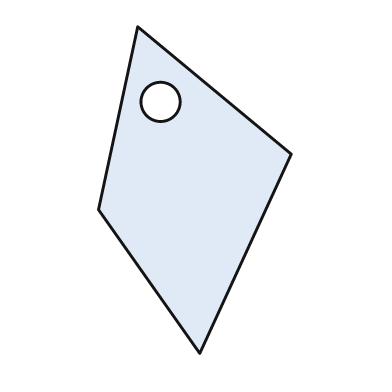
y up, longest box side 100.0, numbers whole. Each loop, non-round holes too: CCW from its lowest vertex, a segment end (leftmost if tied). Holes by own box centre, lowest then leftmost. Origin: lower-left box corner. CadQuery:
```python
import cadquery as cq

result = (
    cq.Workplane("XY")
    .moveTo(31.0, 0.0)
    .lineTo(59.0, 61.0)
    .lineTo(12.0, 100.0)
    .lineTo(0.0, 44.0)
    .close()
    .moveTo(19.0, 77.0)
    .circle(6.0)
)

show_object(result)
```